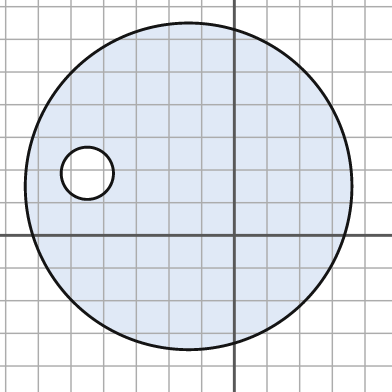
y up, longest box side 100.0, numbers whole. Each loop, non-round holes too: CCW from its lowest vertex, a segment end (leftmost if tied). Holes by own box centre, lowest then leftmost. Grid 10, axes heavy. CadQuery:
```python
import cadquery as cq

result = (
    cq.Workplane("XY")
    .moveTo(-14.0, 15.0)
    .circle(50.0)
    .moveTo(-45.0, 19.0)
    .circle(8.0)
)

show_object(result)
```